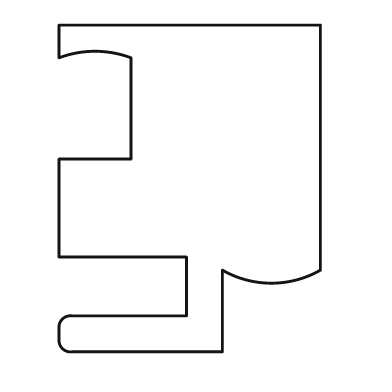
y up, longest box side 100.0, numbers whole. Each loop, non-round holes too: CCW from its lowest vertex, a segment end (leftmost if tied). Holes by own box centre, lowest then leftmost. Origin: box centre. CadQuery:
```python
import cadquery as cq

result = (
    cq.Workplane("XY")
    .moveTo(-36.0, -50.0)
    .lineTo(10.0, -50.0)
    .lineTo(10.0, -25.0)
    .threePointArc((25.0, -29.0), (40.0, -25.0))
    .lineTo(40.0, 50.0)
    .lineTo(-40.0, 50.0)
    .lineTo(-40.0, 40.0)
    .threePointArc((-29.0, 42.0), (-18.0, 40.0))
    .lineTo(-18.0, 9.0)
    .lineTo(-40.0, 9.0)
    .lineTo(-40.0, -21.0)
    .lineTo(-1.0, -21.0)
    .lineTo(-1.0, -39.0)
    .lineTo(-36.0, -39.0)
    .threePointArc((-39.0, -40.0), (-40.0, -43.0))
    .lineTo(-40.0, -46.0)
    .threePointArc((-39.0, -49.0), (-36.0, -50.0))
    .close()
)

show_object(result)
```